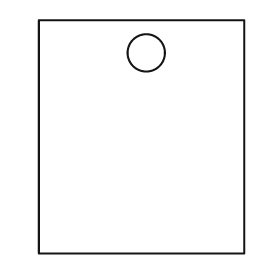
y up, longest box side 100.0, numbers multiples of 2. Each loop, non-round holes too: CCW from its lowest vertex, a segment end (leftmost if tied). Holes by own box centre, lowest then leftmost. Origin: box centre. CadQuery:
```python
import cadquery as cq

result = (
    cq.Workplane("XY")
    .moveTo(-44.0, -50.0)
    .lineTo(44.0, -50.0)
    .lineTo(44.0, 50.0)
    .lineTo(-44.0, 50.0)
    .close()
    .moveTo(2.0, 36.0)
    .circle(8.0)
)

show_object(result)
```